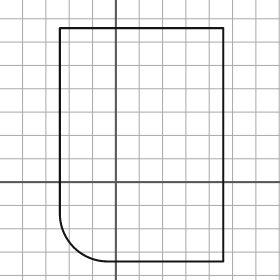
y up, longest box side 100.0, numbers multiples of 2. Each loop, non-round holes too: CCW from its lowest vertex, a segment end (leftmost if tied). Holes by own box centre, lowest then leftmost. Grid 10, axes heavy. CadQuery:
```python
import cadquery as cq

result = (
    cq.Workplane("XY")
    .moveTo(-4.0, -34.0)
    .lineTo(46.0, -34.0)
    .lineTo(46.0, 66.0)
    .lineTo(-24.0, 66.0)
    .lineTo(-24.0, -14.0)
    .threePointArc((-18.0, -28.0), (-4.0, -34.0))
    .close()
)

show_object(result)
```